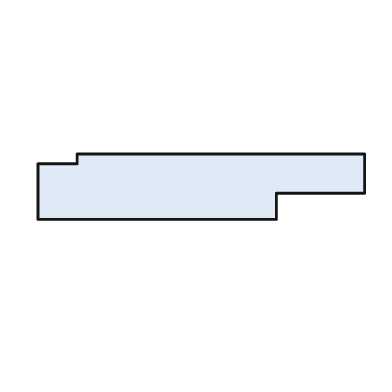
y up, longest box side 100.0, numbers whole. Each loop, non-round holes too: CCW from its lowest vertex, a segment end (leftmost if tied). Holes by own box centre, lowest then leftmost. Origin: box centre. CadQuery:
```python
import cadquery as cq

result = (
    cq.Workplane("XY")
    .moveTo(-50.0, -10.0)
    .lineTo(23.0, -10.0)
    .lineTo(23.0, -2.0)
    .lineTo(50.0, -2.0)
    .lineTo(50.0, 10.0)
    .lineTo(-38.0, 10.0)
    .lineTo(-38.0, 7.0)
    .lineTo(-50.0, 7.0)
    .close()
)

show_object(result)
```